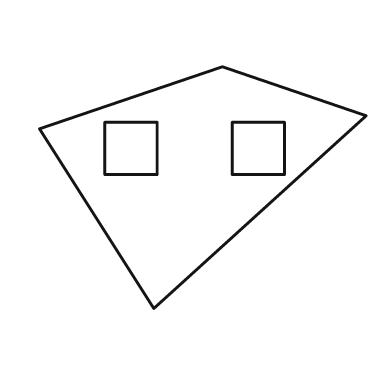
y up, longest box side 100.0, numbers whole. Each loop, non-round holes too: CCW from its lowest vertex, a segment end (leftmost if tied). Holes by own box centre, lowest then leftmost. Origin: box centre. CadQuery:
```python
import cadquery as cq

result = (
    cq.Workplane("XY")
    .moveTo(-15.0, -37.0)
    .lineTo(50.0, 22.0)
    .lineTo(6.0, 37.0)
    .lineTo(-50.0, 18.0)
    .close()
    .moveTo(-30.0, 4.0)
    .lineTo(-14.0, 4.0)
    .lineTo(-14.0, 20.0)
    .lineTo(-30.0, 20.0)
    .close()
    .moveTo(9.0, 4.0)
    .lineTo(25.0, 4.0)
    .lineTo(25.0, 20.0)
    .lineTo(9.0, 20.0)
    .close()
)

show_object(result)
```